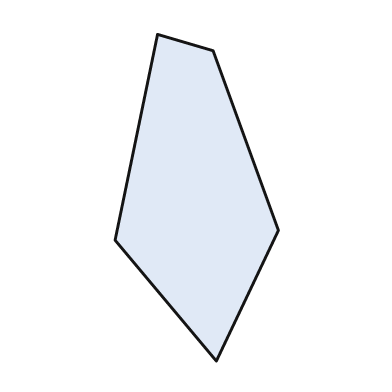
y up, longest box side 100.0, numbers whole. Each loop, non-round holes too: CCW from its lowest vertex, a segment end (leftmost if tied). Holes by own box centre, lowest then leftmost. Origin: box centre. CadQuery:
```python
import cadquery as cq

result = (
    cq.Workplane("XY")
    .moveTo(6.0, -50.0)
    .lineTo(25.0, -10.0)
    .lineTo(5.0, 45.0)
    .lineTo(-12.0, 50.0)
    .lineTo(-25.0, -13.0)
    .close()
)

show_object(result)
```